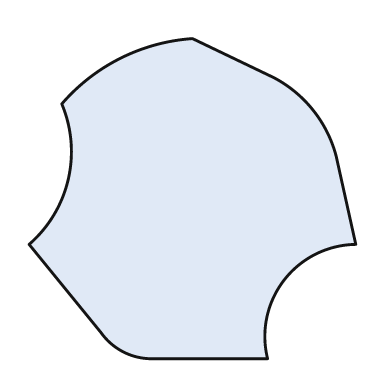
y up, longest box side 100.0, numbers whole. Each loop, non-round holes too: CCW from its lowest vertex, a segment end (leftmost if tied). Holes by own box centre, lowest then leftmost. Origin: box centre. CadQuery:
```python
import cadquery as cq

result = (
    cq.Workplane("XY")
    .moveTo(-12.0, -49.0)
    .lineTo(23.0, -49.0)
    .threePointArc((28.0, -25.0), (50.0, -14.0))
    .lineTo(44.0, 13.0)
    .threePointArc((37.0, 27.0), (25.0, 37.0))
    .lineTo(0.0, 49.0)
    .threePointArc((-22.0, 43.0), (-40.0, 29.0))
    .threePointArc((-38.0, 6.0), (-50.0, -14.0))
    .lineTo(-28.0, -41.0)
    .threePointArc((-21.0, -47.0), (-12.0, -49.0))
    .close()
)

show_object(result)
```